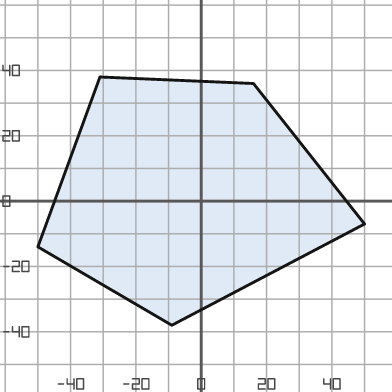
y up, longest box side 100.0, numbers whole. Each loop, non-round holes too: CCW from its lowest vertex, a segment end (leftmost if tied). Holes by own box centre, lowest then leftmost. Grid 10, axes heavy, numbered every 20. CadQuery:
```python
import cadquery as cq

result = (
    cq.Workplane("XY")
    .moveTo(-9.0, -38.0)
    .lineTo(50.0, -7.0)
    .lineTo(16.0, 36.0)
    .lineTo(-31.0, 38.0)
    .lineTo(-50.0, -14.0)
    .close()
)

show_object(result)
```